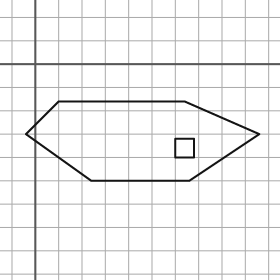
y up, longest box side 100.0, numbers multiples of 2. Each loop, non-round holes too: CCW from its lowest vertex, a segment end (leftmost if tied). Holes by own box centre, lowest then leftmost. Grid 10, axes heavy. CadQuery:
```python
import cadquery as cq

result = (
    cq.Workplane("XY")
    .moveTo(24.0, -50.0)
    .lineTo(66.0, -50.0)
    .lineTo(96.0, -30.0)
    .lineTo(64.0, -16.0)
    .lineTo(10.0, -16.0)
    .lineTo(-4.0, -30.0)
    .close()
    .moveTo(60.0, -40.0)
    .lineTo(68.0, -40.0)
    .lineTo(68.0, -32.0)
    .lineTo(60.0, -32.0)
    .close()
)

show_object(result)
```